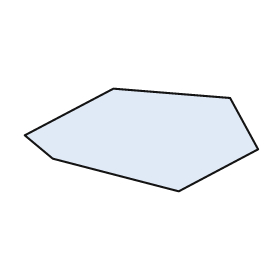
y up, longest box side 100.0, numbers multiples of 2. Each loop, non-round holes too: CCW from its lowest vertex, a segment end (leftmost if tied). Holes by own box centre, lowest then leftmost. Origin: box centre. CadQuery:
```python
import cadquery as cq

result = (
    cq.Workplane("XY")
    .moveTo(16.0, -22.0)
    .lineTo(50.0, -4.0)
    .lineTo(38.0, 18.0)
    .lineTo(-12.0, 22.0)
    .lineTo(-50.0, 2.0)
    .lineTo(-38.0, -8.0)
    .close()
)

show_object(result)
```